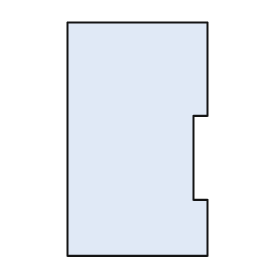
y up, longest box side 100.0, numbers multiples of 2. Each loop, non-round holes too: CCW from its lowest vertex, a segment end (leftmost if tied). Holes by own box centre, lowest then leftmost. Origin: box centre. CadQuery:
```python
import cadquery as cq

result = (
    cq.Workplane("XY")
    .moveTo(-30.0, -50.0)
    .lineTo(30.0, -50.0)
    .lineTo(30.0, -26.0)
    .lineTo(24.0, -26.0)
    .lineTo(24.0, 10.0)
    .lineTo(30.0, 10.0)
    .lineTo(30.0, 50.0)
    .lineTo(-30.0, 50.0)
    .close()
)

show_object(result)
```